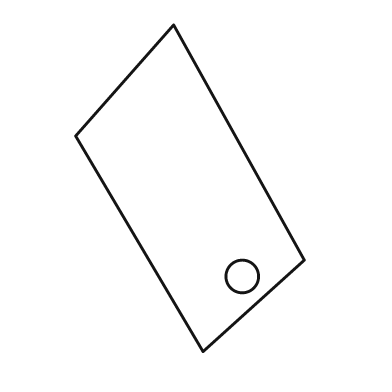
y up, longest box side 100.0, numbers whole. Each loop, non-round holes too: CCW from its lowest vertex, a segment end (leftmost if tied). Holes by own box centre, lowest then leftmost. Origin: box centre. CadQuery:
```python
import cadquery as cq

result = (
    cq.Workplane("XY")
    .moveTo(4.0, -50.0)
    .lineTo(35.0, -22.0)
    .lineTo(-5.0, 50.0)
    .lineTo(-35.0, 16.0)
    .close()
    .moveTo(16.0, -27.0)
    .circle(5.0)
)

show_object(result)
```